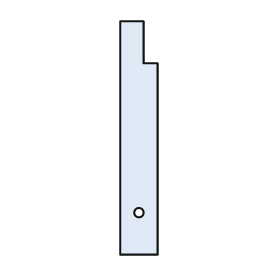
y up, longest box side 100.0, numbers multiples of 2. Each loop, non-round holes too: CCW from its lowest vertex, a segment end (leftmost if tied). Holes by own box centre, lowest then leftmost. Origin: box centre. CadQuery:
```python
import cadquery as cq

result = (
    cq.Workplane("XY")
    .moveTo(-8.0, -50.0)
    .lineTo(8.0, -50.0)
    .lineTo(8.0, 32.0)
    .lineTo(2.0, 32.0)
    .lineTo(2.0, 50.0)
    .lineTo(-8.0, 50.0)
    .close()
    .moveTo(0.0, -32.0)
    .circle(2.0)
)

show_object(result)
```